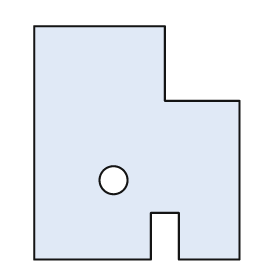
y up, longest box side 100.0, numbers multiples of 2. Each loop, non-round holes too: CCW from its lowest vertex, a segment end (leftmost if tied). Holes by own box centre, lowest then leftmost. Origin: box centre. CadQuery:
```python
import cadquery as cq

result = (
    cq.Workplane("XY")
    .moveTo(-44.0, -50.0)
    .lineTo(6.0, -50.0)
    .lineTo(6.0, -30.0)
    .lineTo(18.0, -30.0)
    .lineTo(18.0, -50.0)
    .lineTo(44.0, -50.0)
    .lineTo(44.0, 18.0)
    .lineTo(12.0, 18.0)
    .lineTo(12.0, 50.0)
    .lineTo(-44.0, 50.0)
    .close()
    .moveTo(-10.0, -16.0)
    .circle(6.0)
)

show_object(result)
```